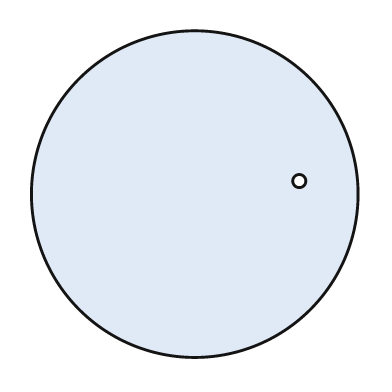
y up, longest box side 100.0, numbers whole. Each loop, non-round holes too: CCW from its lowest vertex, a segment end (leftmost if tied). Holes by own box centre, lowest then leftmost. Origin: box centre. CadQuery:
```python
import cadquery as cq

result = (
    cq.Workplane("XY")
    .moveTo(0.0, 0.0)
    .circle(50.0)
    .moveTo(32.0, 4.0)
    .circle(2.0)
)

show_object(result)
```